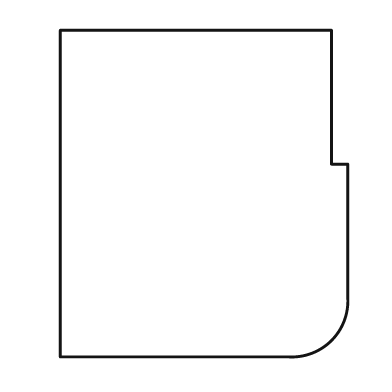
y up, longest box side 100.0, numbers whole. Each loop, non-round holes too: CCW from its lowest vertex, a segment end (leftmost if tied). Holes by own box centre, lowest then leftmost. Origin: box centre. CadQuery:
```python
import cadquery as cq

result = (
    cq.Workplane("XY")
    .moveTo(-44.0, -50.0)
    .lineTo(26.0, -50.0)
    .threePointArc((39.0, -45.0), (44.0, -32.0))
    .lineTo(44.0, 9.0)
    .lineTo(39.0, 9.0)
    .lineTo(39.0, 50.0)
    .lineTo(-44.0, 50.0)
    .close()
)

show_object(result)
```